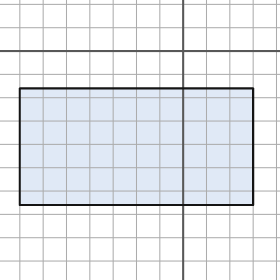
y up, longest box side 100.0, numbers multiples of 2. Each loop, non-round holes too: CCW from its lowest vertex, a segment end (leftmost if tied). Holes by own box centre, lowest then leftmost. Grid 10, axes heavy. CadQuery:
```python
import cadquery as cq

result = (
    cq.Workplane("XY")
    .moveTo(-70.0, -66.0)
    .lineTo(30.0, -66.0)
    .lineTo(30.0, -16.0)
    .lineTo(-70.0, -16.0)
    .close()
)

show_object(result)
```